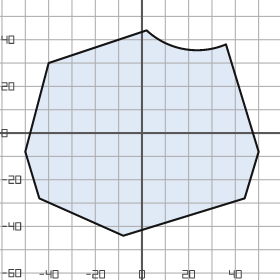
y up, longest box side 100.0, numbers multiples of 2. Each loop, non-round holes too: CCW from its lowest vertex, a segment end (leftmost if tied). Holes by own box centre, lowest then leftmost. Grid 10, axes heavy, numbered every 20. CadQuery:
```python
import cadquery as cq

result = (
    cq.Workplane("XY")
    .moveTo(-8.0, -44.0)
    .lineTo(44.0, -28.0)
    .lineTo(50.0, -8.0)
    .lineTo(36.0, 38.0)
    .threePointArc((18.0, 36.0), (2.0, 44.0))
    .lineTo(-40.0, 30.0)
    .lineTo(-50.0, -8.0)
    .lineTo(-44.0, -28.0)
    .close()
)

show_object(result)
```